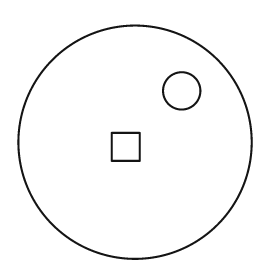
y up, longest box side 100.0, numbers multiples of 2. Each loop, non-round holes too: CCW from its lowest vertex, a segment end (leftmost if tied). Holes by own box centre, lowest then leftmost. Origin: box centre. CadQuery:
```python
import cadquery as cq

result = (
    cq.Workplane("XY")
    .moveTo(0.0, 0.0)
    .circle(50.0)
    .moveTo(-10.0, -8.0)
    .lineTo(2.0, -8.0)
    .lineTo(2.0, 4.0)
    .lineTo(-10.0, 4.0)
    .close()
    .moveTo(20.0, 22.0)
    .circle(8.0)
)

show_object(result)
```